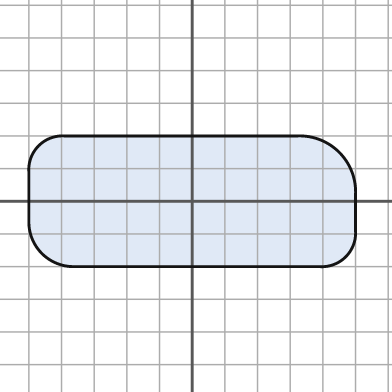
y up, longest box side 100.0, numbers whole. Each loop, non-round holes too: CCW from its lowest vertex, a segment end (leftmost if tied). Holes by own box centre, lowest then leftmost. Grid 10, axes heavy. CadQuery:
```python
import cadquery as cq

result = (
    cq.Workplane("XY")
    .moveTo(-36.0, -20.0)
    .lineTo(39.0, -20.0)
    .threePointArc((47.0, -17.0), (50.0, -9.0))
    .lineTo(50.0, 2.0)
    .threePointArc((45.0, 15.0), (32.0, 20.0))
    .lineTo(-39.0, 20.0)
    .threePointArc((-47.0, 17.0), (-50.0, 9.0))
    .lineTo(-50.0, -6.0)
    .threePointArc((-46.0, -16.0), (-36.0, -20.0))
    .close()
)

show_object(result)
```